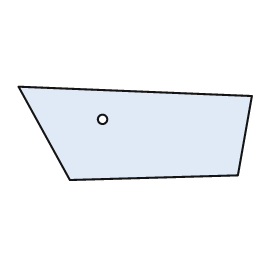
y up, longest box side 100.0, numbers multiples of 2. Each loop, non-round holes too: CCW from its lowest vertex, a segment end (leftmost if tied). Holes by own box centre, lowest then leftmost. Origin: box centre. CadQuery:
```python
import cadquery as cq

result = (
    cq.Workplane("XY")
    .moveTo(-28.0, -20.0)
    .lineTo(44.0, -18.0)
    .lineTo(50.0, 16.0)
    .lineTo(-50.0, 20.0)
    .close()
    .moveTo(-14.0, 6.0)
    .circle(2.0)
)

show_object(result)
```